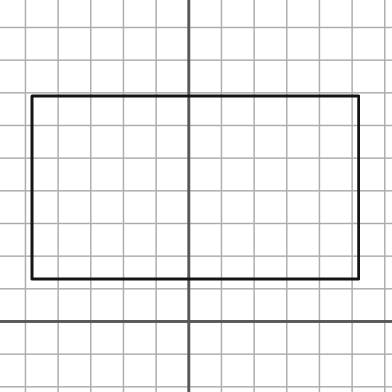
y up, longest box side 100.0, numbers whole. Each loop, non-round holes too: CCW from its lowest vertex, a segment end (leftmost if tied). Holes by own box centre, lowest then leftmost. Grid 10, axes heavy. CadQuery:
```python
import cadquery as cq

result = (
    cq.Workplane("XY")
    .moveTo(-48.0, 13.0)
    .lineTo(52.0, 13.0)
    .lineTo(52.0, 69.0)
    .lineTo(-48.0, 69.0)
    .close()
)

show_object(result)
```